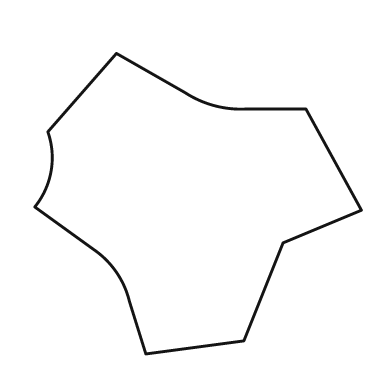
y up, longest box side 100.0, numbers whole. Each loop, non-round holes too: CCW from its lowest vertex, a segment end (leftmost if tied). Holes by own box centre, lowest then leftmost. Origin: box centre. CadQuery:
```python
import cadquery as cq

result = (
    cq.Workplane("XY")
    .moveTo(-16.0, -46.0)
    .lineTo(14.0, -42.0)
    .lineTo(26.0, -12.0)
    .lineTo(50.0, -2.0)
    .lineTo(33.0, 29.0)
    .lineTo(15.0, 29.0)
    .threePointArc((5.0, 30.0), (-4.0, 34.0))
    .lineTo(-25.0, 46.0)
    .lineTo(-46.0, 22.0)
    .threePointArc((-45.0, 10.0), (-50.0, -1.0))
    .lineTo(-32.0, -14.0)
    .threePointArc((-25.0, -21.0), (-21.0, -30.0))
    .close()
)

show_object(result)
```